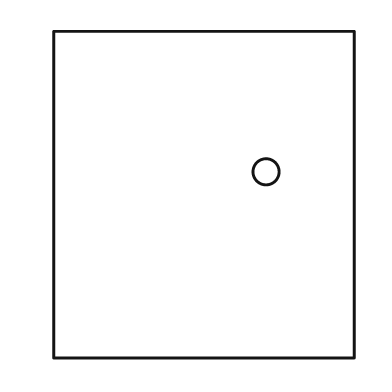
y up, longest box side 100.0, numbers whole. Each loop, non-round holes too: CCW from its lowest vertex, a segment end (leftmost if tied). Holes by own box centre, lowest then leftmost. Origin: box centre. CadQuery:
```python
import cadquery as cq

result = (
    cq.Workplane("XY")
    .moveTo(-46.0, -50.0)
    .lineTo(46.0, -50.0)
    .lineTo(46.0, 50.0)
    .lineTo(-46.0, 50.0)
    .close()
    .moveTo(19.0, 7.0)
    .circle(4.0)
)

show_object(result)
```